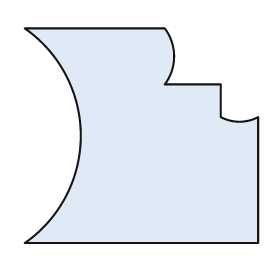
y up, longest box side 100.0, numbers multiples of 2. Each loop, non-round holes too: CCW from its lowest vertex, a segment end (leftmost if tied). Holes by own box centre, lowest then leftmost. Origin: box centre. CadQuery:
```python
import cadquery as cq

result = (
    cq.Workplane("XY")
    .moveTo(-50.0, -46.0)
    .lineTo(50.0, -46.0)
    .lineTo(50.0, 8.0)
    .threePointArc((42.0, 6.0), (34.0, 8.0))
    .lineTo(34.0, 22.0)
    .lineTo(10.0, 22.0)
    .threePointArc((14.0, 34.0), (10.0, 46.0))
    .lineTo(-50.0, 46.0)
    .threePointArc((-26.0, 0.0), (-50.0, -46.0))
    .close()
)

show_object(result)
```